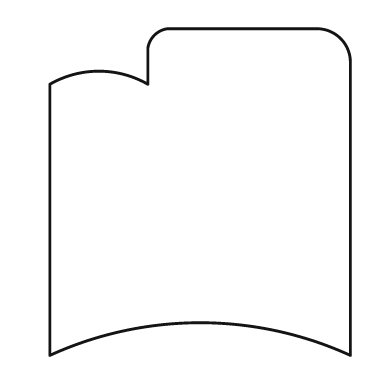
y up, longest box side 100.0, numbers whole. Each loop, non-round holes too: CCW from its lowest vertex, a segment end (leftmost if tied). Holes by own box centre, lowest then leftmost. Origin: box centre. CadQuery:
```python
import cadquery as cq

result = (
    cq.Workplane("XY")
    .moveTo(-46.0, -50.0)
    .threePointArc((0.0, -40.0), (46.0, -50.0))
    .lineTo(46.0, 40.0)
    .threePointArc((43.0, 47.0), (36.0, 50.0))
    .lineTo(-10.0, 50.0)
    .threePointArc((-14.0, 48.0), (-16.0, 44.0))
    .lineTo(-16.0, 33.0)
    .threePointArc((-31.0, 37.0), (-46.0, 33.0))
    .close()
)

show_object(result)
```